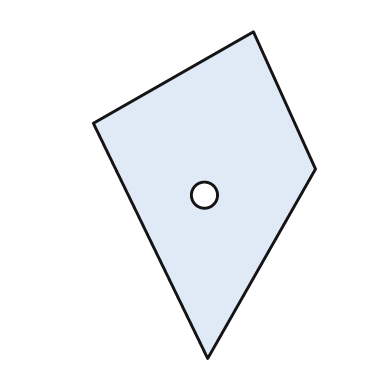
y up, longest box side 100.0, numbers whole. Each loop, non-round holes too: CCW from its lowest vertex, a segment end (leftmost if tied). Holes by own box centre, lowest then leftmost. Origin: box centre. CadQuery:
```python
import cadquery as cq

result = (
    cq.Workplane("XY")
    .moveTo(1.0, -50.0)
    .lineTo(34.0, 8.0)
    .lineTo(15.0, 50.0)
    .lineTo(-34.0, 22.0)
    .close()
    .moveTo(0.0, 0.0)
    .circle(4.0)
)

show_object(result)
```